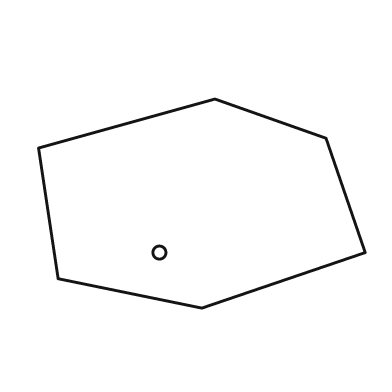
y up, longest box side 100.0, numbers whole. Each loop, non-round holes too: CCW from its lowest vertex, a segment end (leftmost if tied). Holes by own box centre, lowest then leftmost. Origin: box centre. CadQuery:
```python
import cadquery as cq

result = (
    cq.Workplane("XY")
    .moveTo(0.0, -32.0)
    .lineTo(50.0, -15.0)
    .lineTo(38.0, 20.0)
    .lineTo(4.0, 32.0)
    .lineTo(-50.0, 17.0)
    .lineTo(-44.0, -23.0)
    .close()
    .moveTo(-13.0, -15.0)
    .circle(2.0)
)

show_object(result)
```